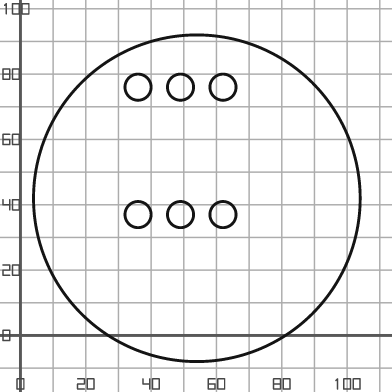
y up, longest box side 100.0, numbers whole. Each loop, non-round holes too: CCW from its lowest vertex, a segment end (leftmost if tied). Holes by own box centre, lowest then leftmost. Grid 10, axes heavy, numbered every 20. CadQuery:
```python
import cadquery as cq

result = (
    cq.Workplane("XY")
    .moveTo(54.0, 42.0)
    .circle(50.0)
    .moveTo(36.0, 37.0)
    .circle(4.0)
    .moveTo(49.0, 37.0)
    .circle(4.0)
    .moveTo(62.0, 37.0)
    .circle(4.0)
    .moveTo(36.0, 76.0)
    .circle(4.0)
    .moveTo(49.0, 76.0)
    .circle(4.0)
    .moveTo(62.0, 76.0)
    .circle(4.0)
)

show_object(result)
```